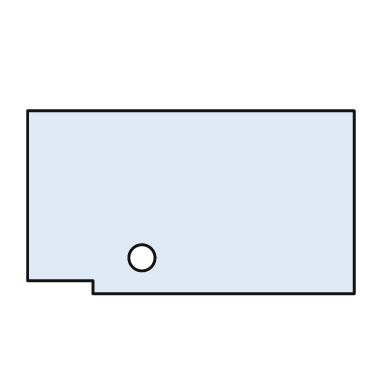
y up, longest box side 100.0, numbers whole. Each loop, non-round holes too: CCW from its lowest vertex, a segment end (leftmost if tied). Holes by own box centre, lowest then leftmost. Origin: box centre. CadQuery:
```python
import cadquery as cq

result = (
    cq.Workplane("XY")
    .moveTo(-30.0, -28.0)
    .lineTo(50.0, -28.0)
    .lineTo(50.0, 28.0)
    .lineTo(-50.0, 28.0)
    .lineTo(-50.0, -24.0)
    .lineTo(-30.0, -24.0)
    .close()
    .moveTo(-15.0, -17.0)
    .circle(4.0)
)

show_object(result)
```